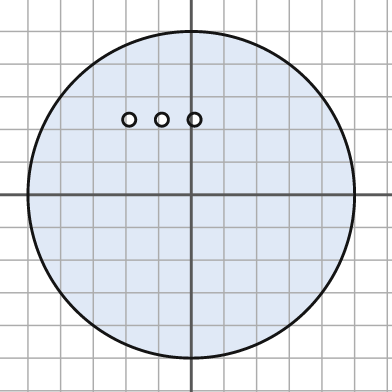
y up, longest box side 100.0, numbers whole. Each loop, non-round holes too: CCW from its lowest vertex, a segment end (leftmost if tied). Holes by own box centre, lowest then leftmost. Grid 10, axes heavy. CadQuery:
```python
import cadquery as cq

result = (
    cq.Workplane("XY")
    .moveTo(0.0, 0.0)
    .circle(50.0)
    .moveTo(-19.0, 23.0)
    .circle(2.0)
    .moveTo(-9.0, 23.0)
    .circle(2.0)
    .moveTo(1.0, 23.0)
    .circle(2.0)
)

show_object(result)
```